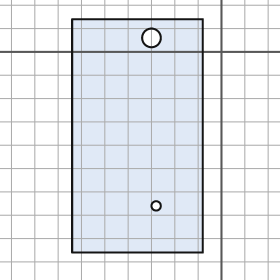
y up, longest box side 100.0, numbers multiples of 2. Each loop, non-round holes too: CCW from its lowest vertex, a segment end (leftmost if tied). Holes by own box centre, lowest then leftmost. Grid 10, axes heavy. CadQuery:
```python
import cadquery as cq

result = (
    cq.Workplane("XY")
    .moveTo(-64.0, -86.0)
    .lineTo(-8.0, -86.0)
    .lineTo(-8.0, 14.0)
    .lineTo(-64.0, 14.0)
    .close()
    .moveTo(-28.0, -66.0)
    .circle(2.0)
    .moveTo(-30.0, 6.0)
    .circle(4.0)
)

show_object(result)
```